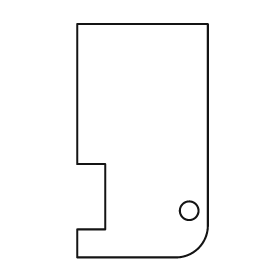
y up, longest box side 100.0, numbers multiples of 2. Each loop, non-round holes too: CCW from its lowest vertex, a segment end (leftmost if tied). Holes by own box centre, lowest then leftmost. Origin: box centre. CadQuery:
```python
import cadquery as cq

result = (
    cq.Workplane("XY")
    .moveTo(-28.0, -50.0)
    .lineTo(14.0, -50.0)
    .threePointArc((24.0, -46.0), (28.0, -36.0))
    .lineTo(28.0, 50.0)
    .lineTo(-28.0, 50.0)
    .lineTo(-28.0, -10.0)
    .lineTo(-16.0, -10.0)
    .lineTo(-16.0, -38.0)
    .lineTo(-28.0, -38.0)
    .close()
    .moveTo(20.0, -30.0)
    .circle(4.0)
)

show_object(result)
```